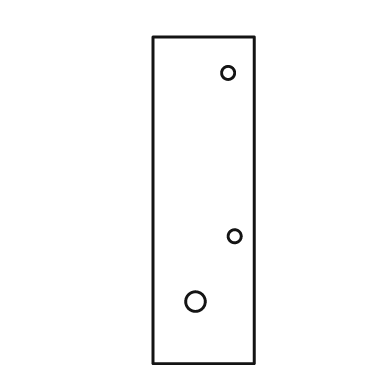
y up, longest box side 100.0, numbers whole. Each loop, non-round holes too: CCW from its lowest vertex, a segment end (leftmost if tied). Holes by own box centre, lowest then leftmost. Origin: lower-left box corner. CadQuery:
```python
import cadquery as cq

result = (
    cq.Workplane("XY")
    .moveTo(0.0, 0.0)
    .lineTo(31.0, 0.0)
    .lineTo(31.0, 100.0)
    .lineTo(0.0, 100.0)
    .close()
    .moveTo(13.0, 19.0)
    .circle(3.0)
    .moveTo(25.0, 39.0)
    .circle(2.0)
    .moveTo(23.0, 89.0)
    .circle(2.0)
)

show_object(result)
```